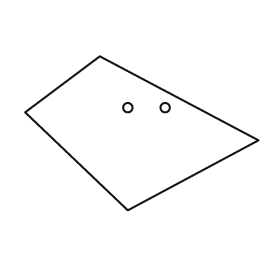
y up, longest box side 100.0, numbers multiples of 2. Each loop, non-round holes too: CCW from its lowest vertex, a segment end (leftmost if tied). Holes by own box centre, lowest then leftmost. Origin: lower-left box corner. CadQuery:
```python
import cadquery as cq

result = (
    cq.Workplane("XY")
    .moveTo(44.0, 0.0)
    .lineTo(100.0, 30.0)
    .lineTo(32.0, 66.0)
    .lineTo(0.0, 42.0)
    .close()
    .moveTo(44.0, 44.0)
    .circle(2.0)
    .moveTo(60.0, 44.0)
    .circle(2.0)
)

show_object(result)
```